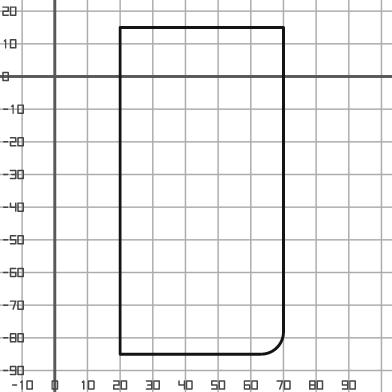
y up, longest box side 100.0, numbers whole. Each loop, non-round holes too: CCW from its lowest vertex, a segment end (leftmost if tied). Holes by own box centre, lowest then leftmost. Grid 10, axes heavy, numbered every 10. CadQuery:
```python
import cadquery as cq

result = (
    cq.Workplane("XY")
    .moveTo(20.0, -85.0)
    .lineTo(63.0, -85.0)
    .threePointArc((68.0, -83.0), (70.0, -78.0))
    .lineTo(70.0, 15.0)
    .lineTo(20.0, 15.0)
    .close()
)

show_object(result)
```